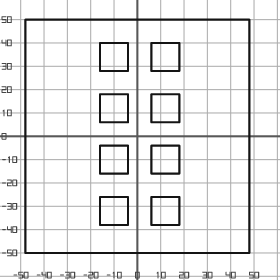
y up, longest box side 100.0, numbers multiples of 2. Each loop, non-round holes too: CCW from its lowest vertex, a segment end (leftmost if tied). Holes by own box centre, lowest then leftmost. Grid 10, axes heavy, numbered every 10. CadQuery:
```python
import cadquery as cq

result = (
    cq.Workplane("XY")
    .moveTo(-48.0, -50.0)
    .lineTo(48.0, -50.0)
    .lineTo(48.0, 50.0)
    .lineTo(-48.0, 50.0)
    .close()
    .moveTo(-16.0, -38.0)
    .lineTo(-4.0, -38.0)
    .lineTo(-4.0, -26.0)
    .lineTo(-16.0, -26.0)
    .close()
    .moveTo(6.0, -38.0)
    .lineTo(18.0, -38.0)
    .lineTo(18.0, -26.0)
    .lineTo(6.0, -26.0)
    .close()
    .moveTo(-16.0, -16.0)
    .lineTo(-4.0, -16.0)
    .lineTo(-4.0, -4.0)
    .lineTo(-16.0, -4.0)
    .close()
    .moveTo(6.0, -16.0)
    .lineTo(18.0, -16.0)
    .lineTo(18.0, -4.0)
    .lineTo(6.0, -4.0)
    .close()
    .moveTo(-16.0, 6.0)
    .lineTo(-4.0, 6.0)
    .lineTo(-4.0, 18.0)
    .lineTo(-16.0, 18.0)
    .close()
    .moveTo(6.0, 6.0)
    .lineTo(18.0, 6.0)
    .lineTo(18.0, 18.0)
    .lineTo(6.0, 18.0)
    .close()
    .moveTo(-16.0, 28.0)
    .lineTo(-4.0, 28.0)
    .lineTo(-4.0, 40.0)
    .lineTo(-16.0, 40.0)
    .close()
    .moveTo(6.0, 28.0)
    .lineTo(18.0, 28.0)
    .lineTo(18.0, 40.0)
    .lineTo(6.0, 40.0)
    .close()
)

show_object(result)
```